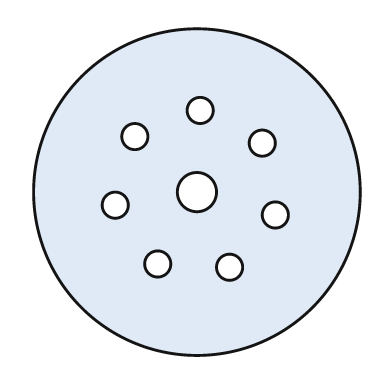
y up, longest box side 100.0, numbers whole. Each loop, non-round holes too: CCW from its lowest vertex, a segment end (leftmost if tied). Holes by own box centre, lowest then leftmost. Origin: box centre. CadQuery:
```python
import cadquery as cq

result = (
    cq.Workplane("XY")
    .moveTo(0.0, 0.0)
    .circle(50.0)
    .moveTo(10.0, -23.0)
    .circle(4.0)
    .moveTo(-12.0, -22.0)
    .circle(4.0)
    .moveTo(24.0, -7.0)
    .circle(4.0)
    .moveTo(-25.0, -4.0)
    .circle(4.0)
    .moveTo(0.0, 0.0)
    .circle(6.0)
    .moveTo(20.0, 15.0)
    .circle(4.0)
    .moveTo(-19.0, 17.0)
    .circle(4.0)
    .moveTo(1.0, 25.0)
    .circle(4.0)
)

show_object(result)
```